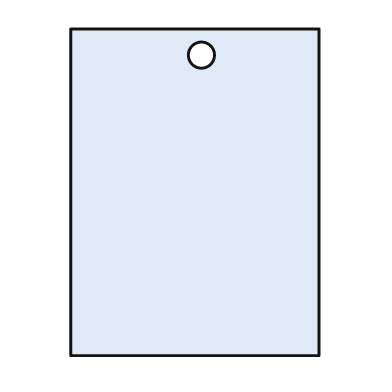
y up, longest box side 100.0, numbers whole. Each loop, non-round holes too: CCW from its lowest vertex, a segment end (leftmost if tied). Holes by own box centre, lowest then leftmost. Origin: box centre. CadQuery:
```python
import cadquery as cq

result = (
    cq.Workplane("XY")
    .moveTo(-38.0, -50.0)
    .lineTo(38.0, -50.0)
    .lineTo(38.0, 50.0)
    .lineTo(-38.0, 50.0)
    .close()
    .moveTo(2.0, 42.0)
    .circle(4.0)
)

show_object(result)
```